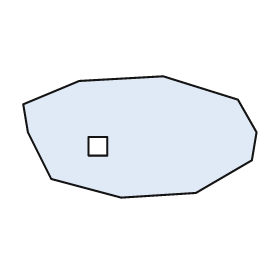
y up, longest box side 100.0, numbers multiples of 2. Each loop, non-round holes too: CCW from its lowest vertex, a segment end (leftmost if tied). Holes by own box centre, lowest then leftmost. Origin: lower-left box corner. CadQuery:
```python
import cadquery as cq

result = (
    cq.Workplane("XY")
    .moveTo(42.0, 0.0)
    .lineTo(74.0, 2.0)
    .lineTo(98.0, 16.0)
    .lineTo(100.0, 28.0)
    .lineTo(92.0, 42.0)
    .lineTo(60.0, 52.0)
    .lineTo(24.0, 50.0)
    .lineTo(0.0, 40.0)
    .lineTo(2.0, 28.0)
    .lineTo(12.0, 8.0)
    .close()
    .moveTo(28.0, 18.0)
    .lineTo(36.0, 18.0)
    .lineTo(36.0, 26.0)
    .lineTo(28.0, 26.0)
    .close()
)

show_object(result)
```